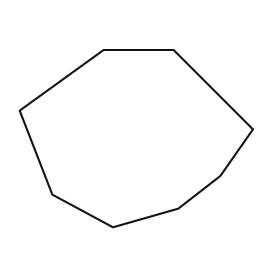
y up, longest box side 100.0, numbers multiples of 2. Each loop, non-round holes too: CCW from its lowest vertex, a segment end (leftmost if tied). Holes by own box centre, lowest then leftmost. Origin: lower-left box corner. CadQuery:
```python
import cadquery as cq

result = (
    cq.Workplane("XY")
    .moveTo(40.0, 0.0)
    .lineTo(68.0, 8.0)
    .lineTo(86.0, 22.0)
    .lineTo(100.0, 42.0)
    .lineTo(66.0, 76.0)
    .lineTo(36.0, 76.0)
    .lineTo(0.0, 50.0)
    .lineTo(14.0, 14.0)
    .close()
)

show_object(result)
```